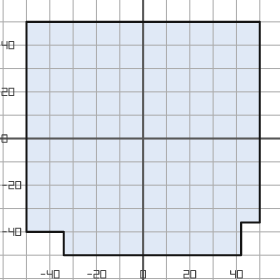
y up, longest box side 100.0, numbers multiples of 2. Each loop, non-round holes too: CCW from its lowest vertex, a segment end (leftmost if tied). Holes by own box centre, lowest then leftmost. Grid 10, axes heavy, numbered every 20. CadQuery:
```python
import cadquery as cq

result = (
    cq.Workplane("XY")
    .moveTo(-34.0, -50.0)
    .lineTo(42.0, -50.0)
    .lineTo(42.0, -36.0)
    .lineTo(50.0, -36.0)
    .lineTo(50.0, 50.0)
    .lineTo(-50.0, 50.0)
    .lineTo(-50.0, -40.0)
    .lineTo(-34.0, -40.0)
    .close()
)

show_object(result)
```